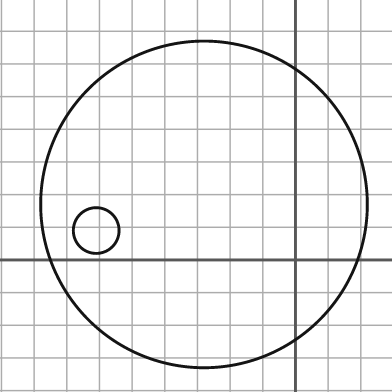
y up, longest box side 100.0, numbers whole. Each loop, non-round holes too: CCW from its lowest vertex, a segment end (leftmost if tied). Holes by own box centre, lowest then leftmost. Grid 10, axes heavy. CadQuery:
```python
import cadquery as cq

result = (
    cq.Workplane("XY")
    .moveTo(-28.0, 17.0)
    .circle(50.0)
    .moveTo(-61.0, 9.0)
    .circle(7.0)
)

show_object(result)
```